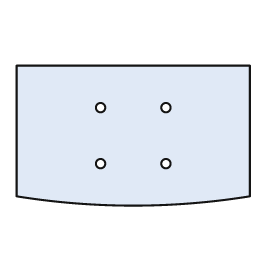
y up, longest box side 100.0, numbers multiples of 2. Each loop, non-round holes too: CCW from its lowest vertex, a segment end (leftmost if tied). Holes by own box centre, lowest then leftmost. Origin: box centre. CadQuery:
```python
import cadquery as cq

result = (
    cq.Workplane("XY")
    .moveTo(-50.0, -26.0)
    .threePointArc((0.0, -30.0), (50.0, -26.0))
    .lineTo(50.0, 30.0)
    .lineTo(-50.0, 30.0)
    .close()
    .moveTo(-14.0, -12.0)
    .circle(2.0)
    .moveTo(14.0, -12.0)
    .circle(2.0)
    .moveTo(-14.0, 12.0)
    .circle(2.0)
    .moveTo(14.0, 12.0)
    .circle(2.0)
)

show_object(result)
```